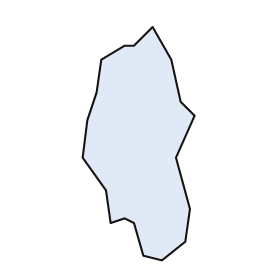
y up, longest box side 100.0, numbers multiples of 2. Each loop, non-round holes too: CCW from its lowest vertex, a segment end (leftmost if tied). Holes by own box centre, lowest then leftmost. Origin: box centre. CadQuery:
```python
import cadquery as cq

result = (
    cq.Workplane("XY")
    .moveTo(10.0, -50.0)
    .lineTo(20.0, -42.0)
    .lineTo(22.0, -28.0)
    .lineTo(16.0, -6.0)
    .lineTo(24.0, 12.0)
    .lineTo(18.0, 18.0)
    .lineTo(14.0, 36.0)
    .lineTo(6.0, 50.0)
    .lineTo(-2.0, 42.0)
    .lineTo(-6.0, 42.0)
    .lineTo(-16.0, 36.0)
    .lineTo(-18.0, 22.0)
    .lineTo(-22.0, 10.0)
    .lineTo(-24.0, -6.0)
    .lineTo(-14.0, -20.0)
    .lineTo(-12.0, -34.0)
    .lineTo(-6.0, -32.0)
    .lineTo(-2.0, -34.0)
    .lineTo(2.0, -48.0)
    .close()
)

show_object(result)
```